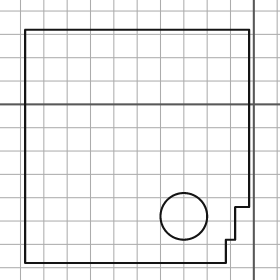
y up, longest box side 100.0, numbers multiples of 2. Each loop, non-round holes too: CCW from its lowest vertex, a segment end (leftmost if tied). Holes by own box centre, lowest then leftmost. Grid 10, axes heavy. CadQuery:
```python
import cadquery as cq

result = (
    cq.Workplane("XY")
    .moveTo(-98.0, -68.0)
    .lineTo(-12.0, -68.0)
    .lineTo(-12.0, -58.0)
    .lineTo(-8.0, -58.0)
    .lineTo(-8.0, -44.0)
    .lineTo(-2.0, -44.0)
    .lineTo(-2.0, 32.0)
    .lineTo(-98.0, 32.0)
    .close()
    .moveTo(-30.0, -48.0)
    .circle(10.0)
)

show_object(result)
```